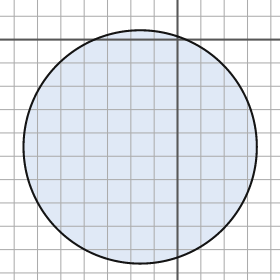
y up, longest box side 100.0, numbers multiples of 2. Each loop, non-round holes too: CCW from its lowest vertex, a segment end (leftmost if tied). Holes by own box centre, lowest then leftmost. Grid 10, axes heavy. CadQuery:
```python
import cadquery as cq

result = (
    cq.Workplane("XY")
    .moveTo(-16.0, -46.0)
    .circle(50.0)
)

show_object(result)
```